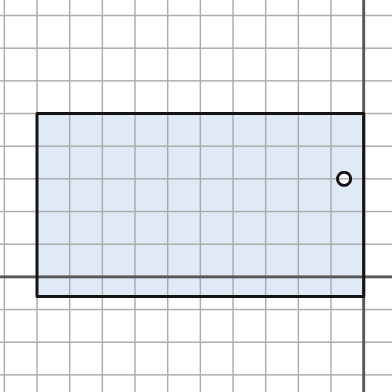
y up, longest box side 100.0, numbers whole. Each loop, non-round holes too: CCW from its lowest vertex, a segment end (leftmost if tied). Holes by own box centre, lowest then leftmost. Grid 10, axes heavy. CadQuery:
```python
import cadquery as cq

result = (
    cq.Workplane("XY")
    .moveTo(-100.0, -6.0)
    .lineTo(0.0, -6.0)
    .lineTo(0.0, 50.0)
    .lineTo(-100.0, 50.0)
    .close()
    .moveTo(-6.0, 30.0)
    .circle(2.0)
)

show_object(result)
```